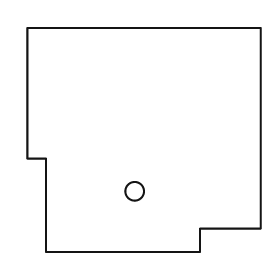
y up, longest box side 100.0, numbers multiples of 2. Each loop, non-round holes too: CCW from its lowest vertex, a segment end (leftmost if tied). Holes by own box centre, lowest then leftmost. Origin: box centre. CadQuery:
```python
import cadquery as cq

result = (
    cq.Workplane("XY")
    .moveTo(-42.0, -48.0)
    .lineTo(24.0, -48.0)
    .lineTo(24.0, -38.0)
    .lineTo(50.0, -38.0)
    .lineTo(50.0, 48.0)
    .lineTo(-50.0, 48.0)
    .lineTo(-50.0, -8.0)
    .lineTo(-42.0, -8.0)
    .close()
    .moveTo(-4.0, -22.0)
    .circle(4.0)
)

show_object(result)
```